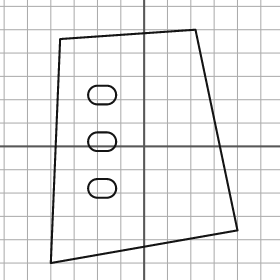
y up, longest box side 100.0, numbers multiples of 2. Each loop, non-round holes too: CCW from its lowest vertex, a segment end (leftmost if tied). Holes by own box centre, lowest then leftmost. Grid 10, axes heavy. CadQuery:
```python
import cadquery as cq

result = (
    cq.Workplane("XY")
    .moveTo(-40.0, -50.0)
    .lineTo(40.0, -36.0)
    .lineTo(22.0, 50.0)
    .lineTo(-36.0, 46.0)
    .close()
    .moveTo(-20.0, -22.0)
    .lineTo(-16.0, -22.0)
    .threePointArc((-12.0, -18.0), (-16.0, -14.0))
    .lineTo(-20.0, -14.0)
    .threePointArc((-24.0, -18.0), (-20.0, -22.0))
    .close()
    .moveTo(-20.0, -2.0)
    .lineTo(-16.0, -2.0)
    .threePointArc((-12.0, 2.0), (-16.0, 6.0))
    .lineTo(-20.0, 6.0)
    .threePointArc((-24.0, 2.0), (-20.0, -2.0))
    .close()
    .moveTo(-20.0, 18.0)
    .lineTo(-16.0, 18.0)
    .threePointArc((-12.0, 22.0), (-16.0, 26.0))
    .lineTo(-20.0, 26.0)
    .threePointArc((-24.0, 22.0), (-20.0, 18.0))
    .close()
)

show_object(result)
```